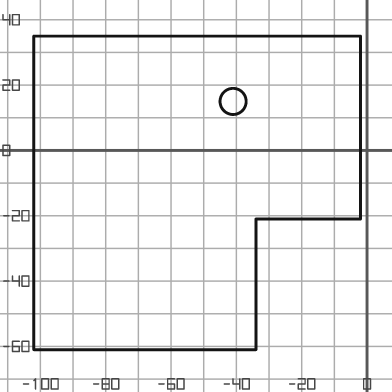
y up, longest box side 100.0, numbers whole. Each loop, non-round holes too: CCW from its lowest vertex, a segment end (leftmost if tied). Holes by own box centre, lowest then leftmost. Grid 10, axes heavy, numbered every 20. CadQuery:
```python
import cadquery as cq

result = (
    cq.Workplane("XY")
    .moveTo(-102.0, -61.0)
    .lineTo(-34.0, -61.0)
    .lineTo(-34.0, -21.0)
    .lineTo(-2.0, -21.0)
    .lineTo(-2.0, 35.0)
    .lineTo(-102.0, 35.0)
    .close()
    .moveTo(-41.0, 15.0)
    .circle(4.0)
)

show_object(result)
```